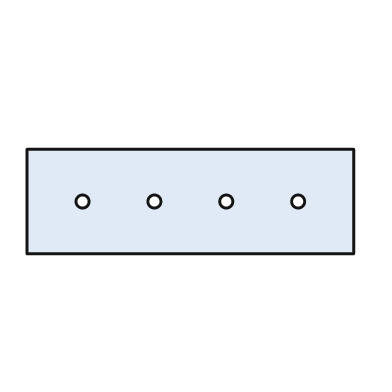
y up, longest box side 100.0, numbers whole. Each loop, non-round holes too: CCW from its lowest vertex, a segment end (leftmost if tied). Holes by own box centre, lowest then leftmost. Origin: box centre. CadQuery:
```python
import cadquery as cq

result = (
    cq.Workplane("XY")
    .moveTo(-50.0, -16.0)
    .lineTo(50.0, -16.0)
    .lineTo(50.0, 16.0)
    .lineTo(-50.0, 16.0)
    .close()
    .moveTo(-33.0, 0.0)
    .circle(2.0)
    .moveTo(-11.0, 0.0)
    .circle(2.0)
    .moveTo(11.0, 0.0)
    .circle(2.0)
    .moveTo(33.0, 0.0)
    .circle(2.0)
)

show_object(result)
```